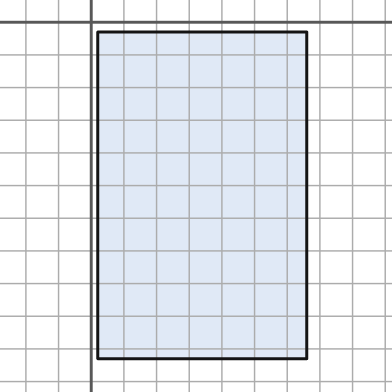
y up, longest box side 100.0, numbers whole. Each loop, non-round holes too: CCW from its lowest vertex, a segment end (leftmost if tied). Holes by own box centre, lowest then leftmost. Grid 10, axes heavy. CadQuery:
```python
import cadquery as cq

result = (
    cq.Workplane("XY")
    .moveTo(2.0, -103.0)
    .lineTo(66.0, -103.0)
    .lineTo(66.0, -3.0)
    .lineTo(2.0, -3.0)
    .close()
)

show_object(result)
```